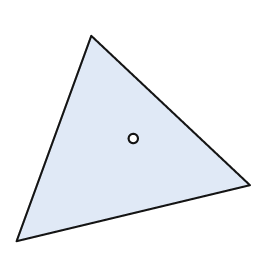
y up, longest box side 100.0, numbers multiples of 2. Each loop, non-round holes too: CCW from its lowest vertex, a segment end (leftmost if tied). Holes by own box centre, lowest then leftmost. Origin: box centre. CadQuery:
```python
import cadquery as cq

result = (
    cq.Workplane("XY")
    .moveTo(-50.0, -44.0)
    .lineTo(50.0, -20.0)
    .lineTo(-18.0, 44.0)
    .close()
    .moveTo(0.0, 0.0)
    .circle(2.0)
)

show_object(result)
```